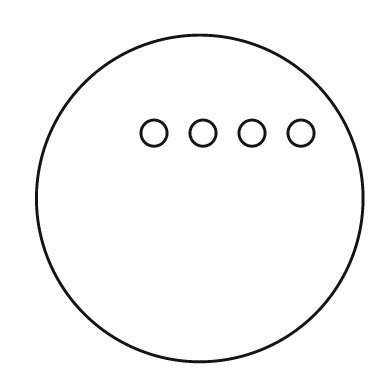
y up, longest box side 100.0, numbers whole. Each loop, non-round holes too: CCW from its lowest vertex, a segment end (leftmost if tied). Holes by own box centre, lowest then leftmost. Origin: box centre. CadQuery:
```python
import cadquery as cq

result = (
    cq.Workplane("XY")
    .moveTo(0.0, 0.0)
    .circle(50.0)
    .moveTo(-14.0, 20.0)
    .circle(4.0)
    .moveTo(1.0, 20.0)
    .circle(4.0)
    .moveTo(16.0, 20.0)
    .circle(4.0)
    .moveTo(31.0, 20.0)
    .circle(4.0)
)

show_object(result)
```